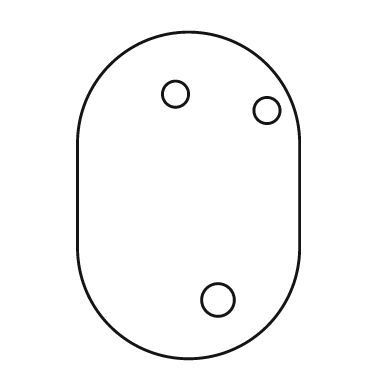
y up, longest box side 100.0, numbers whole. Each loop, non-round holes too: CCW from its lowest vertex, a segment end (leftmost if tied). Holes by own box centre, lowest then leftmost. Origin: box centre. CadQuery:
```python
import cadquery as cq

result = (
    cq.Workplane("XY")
    .moveTo(-34.0, -16.0)
    .threePointArc((0.0, -50.0), (34.0, -16.0))
    .lineTo(34.0, 16.0)
    .threePointArc((0.0, 50.0), (-34.0, 16.0))
    .close()
    .moveTo(9.0, -32.0)
    .circle(5.0)
    .moveTo(24.0, 26.0)
    .circle(4.0)
    .moveTo(-4.0, 31.0)
    .circle(4.0)
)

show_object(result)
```